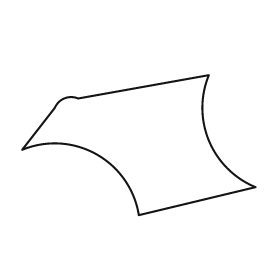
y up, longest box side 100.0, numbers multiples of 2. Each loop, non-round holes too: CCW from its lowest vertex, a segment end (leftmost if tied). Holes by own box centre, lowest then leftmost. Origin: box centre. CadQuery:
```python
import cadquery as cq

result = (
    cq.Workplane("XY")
    .moveTo(0.0, -30.0)
    .lineTo(50.0, -18.0)
    .threePointArc((30.0, 2.0), (30.0, 30.0))
    .lineTo(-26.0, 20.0)
    .threePointArc((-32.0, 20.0), (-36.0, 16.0))
    .lineTo(-50.0, -2.0)
    .threePointArc((-18.0, -4.0), (0.0, -30.0))
    .close()
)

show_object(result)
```